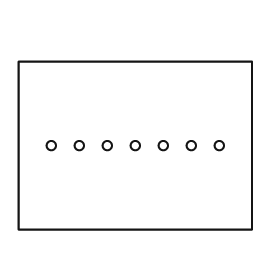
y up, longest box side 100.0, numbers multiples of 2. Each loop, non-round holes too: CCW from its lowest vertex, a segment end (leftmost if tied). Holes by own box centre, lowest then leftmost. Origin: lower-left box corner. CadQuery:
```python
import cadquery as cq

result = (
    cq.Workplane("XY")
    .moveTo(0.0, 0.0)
    .lineTo(100.0, 0.0)
    .lineTo(100.0, 72.0)
    .lineTo(0.0, 72.0)
    .close()
    .moveTo(14.0, 36.0)
    .circle(2.0)
    .moveTo(26.0, 36.0)
    .circle(2.0)
    .moveTo(38.0, 36.0)
    .circle(2.0)
    .moveTo(50.0, 36.0)
    .circle(2.0)
    .moveTo(62.0, 36.0)
    .circle(2.0)
    .moveTo(74.0, 36.0)
    .circle(2.0)
    .moveTo(86.0, 36.0)
    .circle(2.0)
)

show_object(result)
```